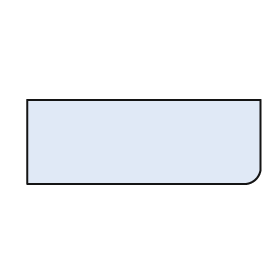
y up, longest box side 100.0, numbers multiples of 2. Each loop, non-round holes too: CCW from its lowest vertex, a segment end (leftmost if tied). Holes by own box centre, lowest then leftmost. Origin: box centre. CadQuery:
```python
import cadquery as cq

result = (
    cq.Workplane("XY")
    .moveTo(-50.0, -18.0)
    .lineTo(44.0, -18.0)
    .threePointArc((48.0, -16.0), (50.0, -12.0))
    .lineTo(50.0, 18.0)
    .lineTo(-50.0, 18.0)
    .close()
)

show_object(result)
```